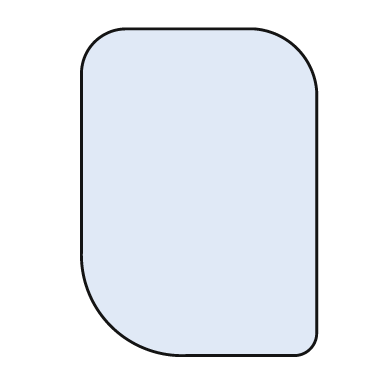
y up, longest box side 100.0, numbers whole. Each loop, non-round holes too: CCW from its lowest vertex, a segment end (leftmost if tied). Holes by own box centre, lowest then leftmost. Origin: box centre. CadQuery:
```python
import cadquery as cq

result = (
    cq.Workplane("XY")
    .moveTo(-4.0, -50.0)
    .lineTo(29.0, -50.0)
    .threePointArc((34.0, -48.0), (36.0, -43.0))
    .lineTo(36.0, 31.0)
    .threePointArc((30.0, 44.0), (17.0, 50.0))
    .lineTo(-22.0, 50.0)
    .threePointArc((-32.0, 46.0), (-36.0, 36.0))
    .lineTo(-36.0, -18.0)
    .threePointArc((-27.0, -41.0), (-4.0, -50.0))
    .close()
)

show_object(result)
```